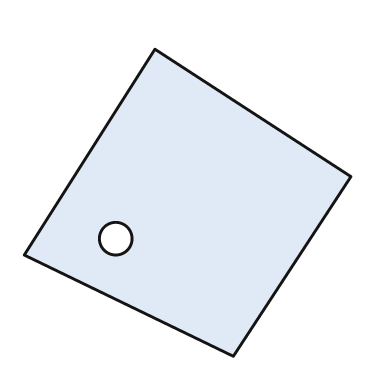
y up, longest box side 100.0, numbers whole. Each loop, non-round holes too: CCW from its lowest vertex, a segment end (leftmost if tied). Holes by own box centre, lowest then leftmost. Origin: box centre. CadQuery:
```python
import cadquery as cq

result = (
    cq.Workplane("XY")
    .moveTo(14.0, -47.0)
    .lineTo(50.0, 8.0)
    .lineTo(-10.0, 47.0)
    .lineTo(-50.0, -16.0)
    .close()
    .moveTo(-22.0, -11.0)
    .circle(5.0)
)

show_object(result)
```